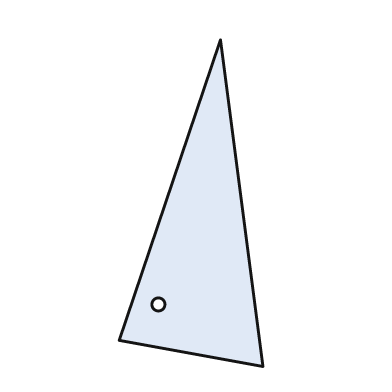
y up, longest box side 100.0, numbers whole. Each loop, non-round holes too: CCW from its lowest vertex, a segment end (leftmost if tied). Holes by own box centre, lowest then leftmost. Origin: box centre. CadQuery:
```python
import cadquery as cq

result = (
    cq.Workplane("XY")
    .moveTo(22.0, -50.0)
    .lineTo(9.0, 50.0)
    .lineTo(-22.0, -42.0)
    .close()
    .moveTo(-10.0, -31.0)
    .circle(2.0)
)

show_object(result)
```